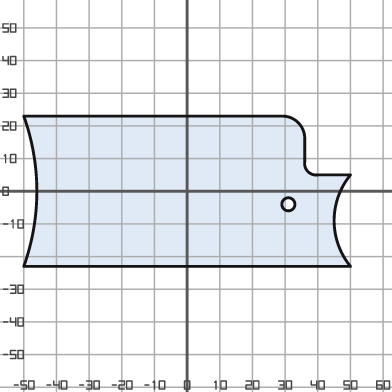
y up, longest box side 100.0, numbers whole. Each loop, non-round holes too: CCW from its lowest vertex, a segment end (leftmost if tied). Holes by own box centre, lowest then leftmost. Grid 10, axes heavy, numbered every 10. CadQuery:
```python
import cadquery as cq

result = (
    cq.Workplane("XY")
    .moveTo(-50.0, -23.0)
    .lineTo(50.0, -23.0)
    .threePointArc((45.0, -9.0), (50.0, 5.0))
    .lineTo(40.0, 5.0)
    .threePointArc((37.0, 6.0), (36.0, 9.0))
    .lineTo(36.0, 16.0)
    .threePointArc((34.0, 21.0), (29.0, 23.0))
    .lineTo(-50.0, 23.0)
    .threePointArc((-46.0, 0.0), (-50.0, -23.0))
    .close()
    .moveTo(31.0, -4.0)
    .circle(2.0)
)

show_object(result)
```